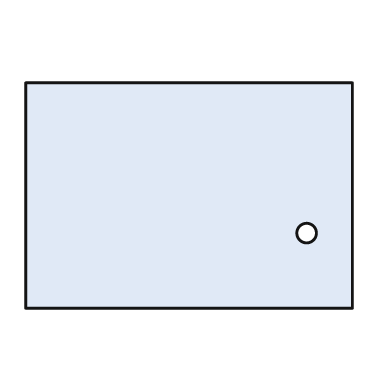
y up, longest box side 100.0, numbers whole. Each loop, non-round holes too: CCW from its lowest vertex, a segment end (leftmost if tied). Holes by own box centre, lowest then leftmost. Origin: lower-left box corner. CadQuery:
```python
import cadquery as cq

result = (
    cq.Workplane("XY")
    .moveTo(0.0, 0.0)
    .lineTo(100.0, 0.0)
    .lineTo(100.0, 69.0)
    .lineTo(0.0, 69.0)
    .close()
    .moveTo(86.0, 23.0)
    .circle(3.0)
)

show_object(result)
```